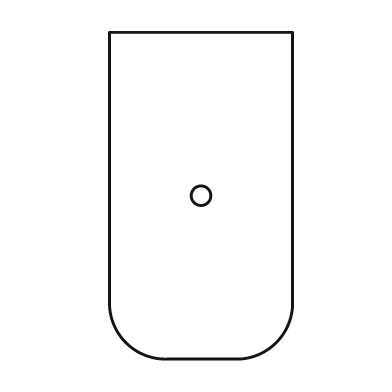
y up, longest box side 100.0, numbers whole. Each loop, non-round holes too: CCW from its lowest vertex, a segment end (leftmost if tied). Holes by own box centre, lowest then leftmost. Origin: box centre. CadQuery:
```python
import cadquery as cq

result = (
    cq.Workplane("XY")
    .moveTo(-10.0, -50.0)
    .lineTo(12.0, -50.0)
    .threePointArc((23.0, -45.0), (28.0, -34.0))
    .lineTo(28.0, 50.0)
    .lineTo(-28.0, 50.0)
    .lineTo(-28.0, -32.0)
    .threePointArc((-23.0, -45.0), (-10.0, -50.0))
    .close()
    .moveTo(0.0, 0.0)
    .circle(3.0)
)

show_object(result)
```